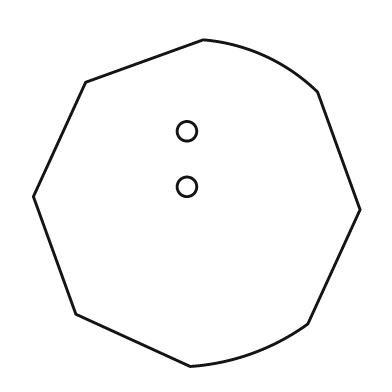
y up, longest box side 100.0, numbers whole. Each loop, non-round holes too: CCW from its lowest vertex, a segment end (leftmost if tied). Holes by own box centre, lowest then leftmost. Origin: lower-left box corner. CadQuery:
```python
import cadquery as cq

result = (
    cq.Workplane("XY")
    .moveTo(48.0, 0.0)
    .threePointArc((67.0, 4.0), (84.0, 13.0))
    .lineTo(100.0, 48.0)
    .lineTo(87.0, 84.0)
    .threePointArc((71.0, 95.0), (52.0, 100.0))
    .lineTo(16.0, 87.0)
    .lineTo(0.0, 52.0)
    .lineTo(13.0, 16.0)
    .close()
    .moveTo(47.0, 55.0)
    .circle(3.0)
    .moveTo(47.0, 72.0)
    .circle(3.0)
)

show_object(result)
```